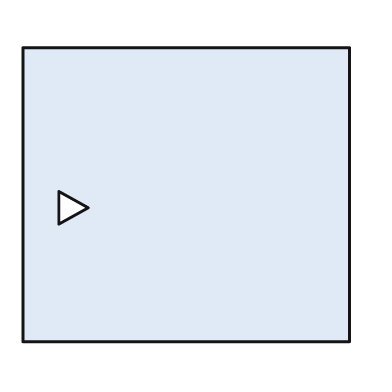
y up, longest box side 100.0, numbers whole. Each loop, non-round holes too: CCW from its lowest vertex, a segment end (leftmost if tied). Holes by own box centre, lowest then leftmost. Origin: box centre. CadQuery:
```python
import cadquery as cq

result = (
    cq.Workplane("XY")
    .moveTo(-50.0, -45.0)
    .lineTo(50.0, -45.0)
    .lineTo(50.0, 45.0)
    .lineTo(-50.0, 45.0)
    .close()
    .moveTo(-39.0, -9.0)
    .lineTo(-30.0, -4.0)
    .lineTo(-39.0, 1.0)
    .close()
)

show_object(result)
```